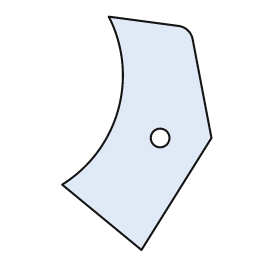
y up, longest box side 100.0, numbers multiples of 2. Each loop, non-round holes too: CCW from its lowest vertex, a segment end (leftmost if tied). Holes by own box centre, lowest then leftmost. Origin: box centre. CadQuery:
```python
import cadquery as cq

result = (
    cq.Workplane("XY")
    .moveTo(2.0, -50.0)
    .lineTo(32.0, -2.0)
    .lineTo(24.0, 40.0)
    .threePointArc((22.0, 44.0), (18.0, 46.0))
    .lineTo(-12.0, 50.0)
    .threePointArc((-8.0, 10.0), (-32.0, -22.0))
    .close()
    .moveTo(10.0, -2.0)
    .circle(4.0)
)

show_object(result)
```